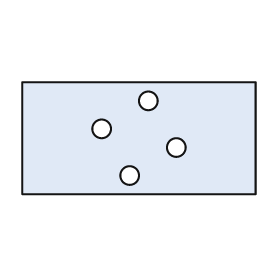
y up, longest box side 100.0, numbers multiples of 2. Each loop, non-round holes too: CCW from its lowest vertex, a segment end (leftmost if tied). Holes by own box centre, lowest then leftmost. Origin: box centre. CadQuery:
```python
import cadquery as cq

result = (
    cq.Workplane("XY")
    .moveTo(-50.0, -24.0)
    .lineTo(50.0, -24.0)
    .lineTo(50.0, 24.0)
    .lineTo(-50.0, 24.0)
    .close()
    .moveTo(-4.0, -16.0)
    .circle(4.0)
    .moveTo(16.0, -4.0)
    .circle(4.0)
    .moveTo(-16.0, 4.0)
    .circle(4.0)
    .moveTo(4.0, 16.0)
    .circle(4.0)
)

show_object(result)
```